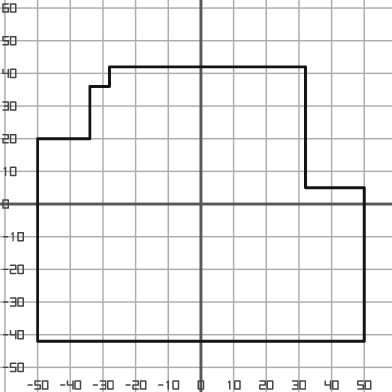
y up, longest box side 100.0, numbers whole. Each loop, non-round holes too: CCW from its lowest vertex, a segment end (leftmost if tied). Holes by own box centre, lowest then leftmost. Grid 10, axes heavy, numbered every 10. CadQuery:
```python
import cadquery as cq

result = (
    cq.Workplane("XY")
    .moveTo(-50.0, -42.0)
    .lineTo(50.0, -42.0)
    .lineTo(50.0, 5.0)
    .lineTo(32.0, 5.0)
    .lineTo(32.0, 42.0)
    .lineTo(-28.0, 42.0)
    .lineTo(-28.0, 36.0)
    .lineTo(-34.0, 36.0)
    .lineTo(-34.0, 20.0)
    .lineTo(-50.0, 20.0)
    .close()
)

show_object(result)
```